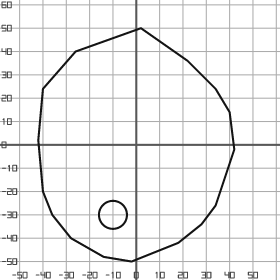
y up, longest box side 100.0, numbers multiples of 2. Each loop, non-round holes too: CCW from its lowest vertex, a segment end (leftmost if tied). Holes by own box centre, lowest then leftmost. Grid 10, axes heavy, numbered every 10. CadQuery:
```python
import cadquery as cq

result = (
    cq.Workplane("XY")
    .moveTo(-2.0, -50.0)
    .lineTo(18.0, -42.0)
    .lineTo(28.0, -34.0)
    .lineTo(34.0, -26.0)
    .lineTo(42.0, -2.0)
    .lineTo(40.0, 14.0)
    .lineTo(34.0, 24.0)
    .lineTo(22.0, 36.0)
    .lineTo(2.0, 50.0)
    .lineTo(-26.0, 40.0)
    .lineTo(-40.0, 24.0)
    .lineTo(-42.0, 2.0)
    .lineTo(-40.0, -20.0)
    .lineTo(-36.0, -30.0)
    .lineTo(-28.0, -40.0)
    .lineTo(-14.0, -48.0)
    .close()
    .moveTo(-10.0, -30.0)
    .circle(6.0)
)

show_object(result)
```